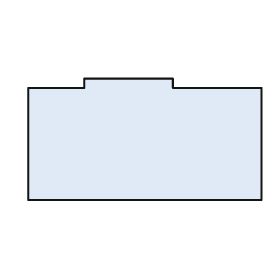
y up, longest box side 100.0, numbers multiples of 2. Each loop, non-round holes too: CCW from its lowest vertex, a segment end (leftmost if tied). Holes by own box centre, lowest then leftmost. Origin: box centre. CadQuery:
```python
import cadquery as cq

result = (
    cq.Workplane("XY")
    .moveTo(-50.0, -26.0)
    .lineTo(50.0, -26.0)
    .lineTo(50.0, 22.0)
    .lineTo(12.0, 22.0)
    .lineTo(12.0, 26.0)
    .lineTo(-26.0, 26.0)
    .lineTo(-26.0, 22.0)
    .lineTo(-50.0, 22.0)
    .close()
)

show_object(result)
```